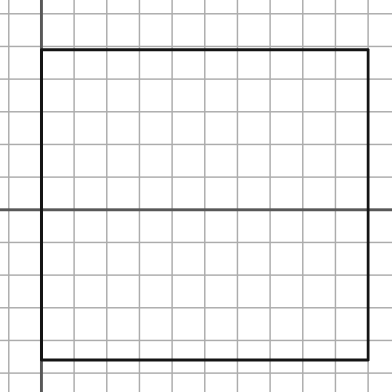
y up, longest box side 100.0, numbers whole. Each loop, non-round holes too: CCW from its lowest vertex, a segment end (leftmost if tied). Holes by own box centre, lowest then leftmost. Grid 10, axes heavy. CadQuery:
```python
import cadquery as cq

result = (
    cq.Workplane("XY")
    .moveTo(0.0, -46.0)
    .lineTo(100.0, -46.0)
    .lineTo(100.0, 49.0)
    .lineTo(0.0, 49.0)
    .close()
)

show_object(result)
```